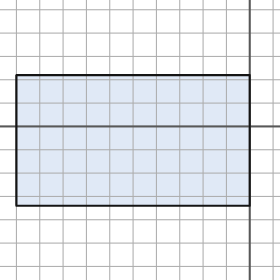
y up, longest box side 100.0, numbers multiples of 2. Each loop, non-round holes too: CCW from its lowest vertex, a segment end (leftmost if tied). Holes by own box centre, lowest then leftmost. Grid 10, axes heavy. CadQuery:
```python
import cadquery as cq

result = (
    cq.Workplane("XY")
    .moveTo(-100.0, -34.0)
    .lineTo(0.0, -34.0)
    .lineTo(0.0, 22.0)
    .lineTo(-100.0, 22.0)
    .close()
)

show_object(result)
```